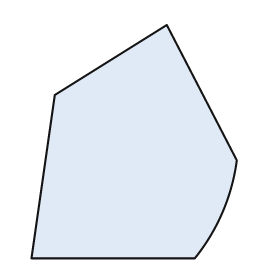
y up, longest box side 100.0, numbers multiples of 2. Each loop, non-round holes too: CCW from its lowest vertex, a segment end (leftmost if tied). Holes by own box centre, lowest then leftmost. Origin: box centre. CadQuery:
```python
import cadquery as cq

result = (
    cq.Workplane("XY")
    .moveTo(-44.0, -50.0)
    .lineTo(26.0, -50.0)
    .threePointArc((38.0, -30.0), (44.0, -8.0))
    .lineTo(14.0, 50.0)
    .lineTo(-34.0, 20.0)
    .close()
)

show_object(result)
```